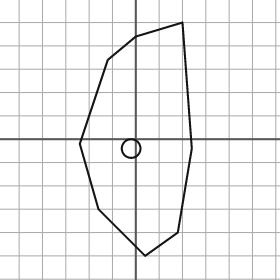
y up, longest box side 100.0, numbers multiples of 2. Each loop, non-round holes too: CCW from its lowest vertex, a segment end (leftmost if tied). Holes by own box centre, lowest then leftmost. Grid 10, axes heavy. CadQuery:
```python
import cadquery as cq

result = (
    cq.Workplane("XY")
    .moveTo(4.0, -50.0)
    .lineTo(18.0, -40.0)
    .lineTo(24.0, -4.0)
    .lineTo(20.0, 50.0)
    .lineTo(0.0, 44.0)
    .lineTo(-12.0, 34.0)
    .lineTo(-24.0, -2.0)
    .lineTo(-16.0, -30.0)
    .close()
    .moveTo(-2.0, -4.0)
    .circle(4.0)
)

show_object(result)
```